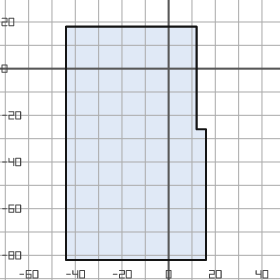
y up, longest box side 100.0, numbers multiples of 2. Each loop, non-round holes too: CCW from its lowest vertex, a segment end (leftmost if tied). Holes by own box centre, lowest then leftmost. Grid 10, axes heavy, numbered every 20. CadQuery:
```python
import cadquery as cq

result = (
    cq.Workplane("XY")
    .moveTo(-44.0, -82.0)
    .lineTo(16.0, -82.0)
    .lineTo(16.0, -26.0)
    .lineTo(12.0, -26.0)
    .lineTo(12.0, 18.0)
    .lineTo(-44.0, 18.0)
    .close()
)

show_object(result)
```